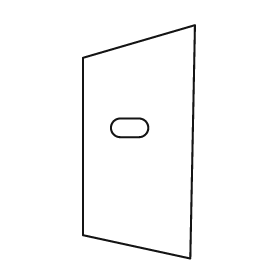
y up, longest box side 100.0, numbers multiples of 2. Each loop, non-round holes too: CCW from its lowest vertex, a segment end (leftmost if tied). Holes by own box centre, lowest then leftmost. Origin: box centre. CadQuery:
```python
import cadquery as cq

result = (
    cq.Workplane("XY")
    .moveTo(22.0, -50.0)
    .lineTo(24.0, 50.0)
    .lineTo(-24.0, 36.0)
    .lineTo(-24.0, -40.0)
    .close()
    .moveTo(-8.0, 2.0)
    .lineTo(0.0, 2.0)
    .threePointArc((4.0, 6.0), (0.0, 10.0))
    .lineTo(-8.0, 10.0)
    .threePointArc((-12.0, 6.0), (-8.0, 2.0))
    .close()
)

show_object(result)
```